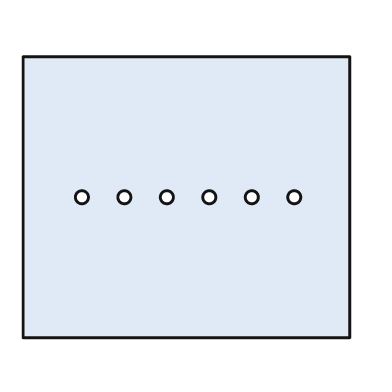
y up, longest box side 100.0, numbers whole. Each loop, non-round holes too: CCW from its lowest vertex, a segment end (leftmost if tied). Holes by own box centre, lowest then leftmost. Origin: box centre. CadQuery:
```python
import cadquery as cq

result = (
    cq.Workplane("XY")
    .moveTo(-50.0, -43.0)
    .lineTo(50.0, -43.0)
    .lineTo(50.0, 43.0)
    .lineTo(-50.0, 43.0)
    .close()
    .moveTo(-32.0, 0.0)
    .circle(2.0)
    .moveTo(-19.0, 0.0)
    .circle(2.0)
    .moveTo(-6.0, 0.0)
    .circle(2.0)
    .moveTo(7.0, 0.0)
    .circle(2.0)
    .moveTo(20.0, 0.0)
    .circle(2.0)
    .moveTo(33.0, 0.0)
    .circle(2.0)
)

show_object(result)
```